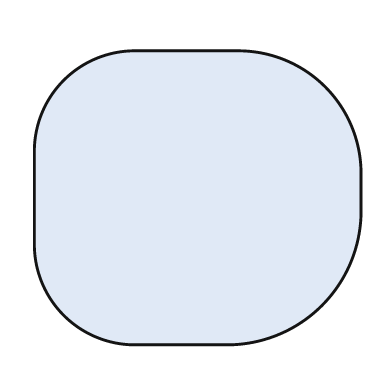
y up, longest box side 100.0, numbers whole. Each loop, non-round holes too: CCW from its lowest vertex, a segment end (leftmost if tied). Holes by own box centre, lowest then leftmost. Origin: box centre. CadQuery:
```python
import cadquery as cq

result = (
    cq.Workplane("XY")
    .moveTo(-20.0, -45.0)
    .lineTo(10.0, -45.0)
    .threePointArc((38.0, -33.0), (50.0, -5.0))
    .lineTo(50.0, 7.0)
    .threePointArc((39.0, 34.0), (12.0, 45.0))
    .lineTo(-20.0, 45.0)
    .threePointArc((-41.0, 36.0), (-50.0, 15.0))
    .lineTo(-50.0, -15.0)
    .threePointArc((-41.0, -36.0), (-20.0, -45.0))
    .close()
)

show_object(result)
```